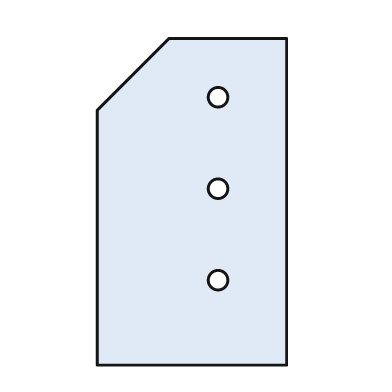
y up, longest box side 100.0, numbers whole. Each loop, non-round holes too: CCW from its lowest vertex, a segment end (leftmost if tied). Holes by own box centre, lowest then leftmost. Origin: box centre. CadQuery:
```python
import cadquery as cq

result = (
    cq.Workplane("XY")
    .moveTo(-29.0, -50.0)
    .lineTo(29.0, -50.0)
    .lineTo(29.0, 50.0)
    .lineTo(-7.0, 50.0)
    .lineTo(-29.0, 28.0)
    .close()
    .moveTo(8.0, -24.0)
    .circle(3.0)
    .moveTo(8.0, 4.0)
    .circle(3.0)
    .moveTo(8.0, 32.0)
    .circle(3.0)
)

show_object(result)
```